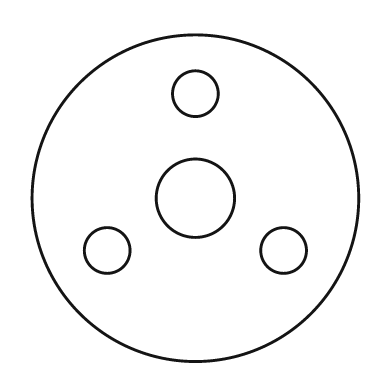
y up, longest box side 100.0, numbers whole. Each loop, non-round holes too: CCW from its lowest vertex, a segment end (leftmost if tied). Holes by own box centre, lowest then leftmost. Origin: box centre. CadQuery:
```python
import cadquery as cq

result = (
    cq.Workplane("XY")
    .moveTo(0.0, 0.0)
    .circle(50.0)
    .moveTo(-27.0, -16.0)
    .circle(7.0)
    .moveTo(27.0, -16.0)
    .circle(7.0)
    .moveTo(0.0, 0.0)
    .circle(12.0)
    .moveTo(0.0, 32.0)
    .circle(7.0)
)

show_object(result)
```